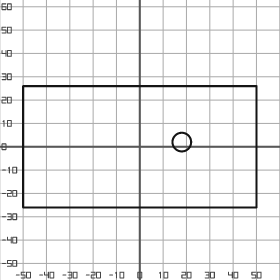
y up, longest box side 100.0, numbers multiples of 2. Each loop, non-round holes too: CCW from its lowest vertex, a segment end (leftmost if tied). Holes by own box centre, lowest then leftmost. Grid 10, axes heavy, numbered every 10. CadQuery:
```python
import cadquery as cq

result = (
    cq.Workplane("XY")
    .moveTo(-50.0, -26.0)
    .lineTo(50.0, -26.0)
    .lineTo(50.0, 26.0)
    .lineTo(-50.0, 26.0)
    .close()
    .moveTo(18.0, 2.0)
    .circle(4.0)
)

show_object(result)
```